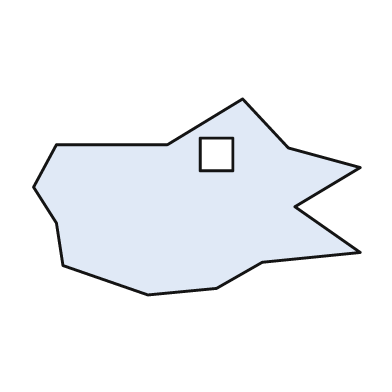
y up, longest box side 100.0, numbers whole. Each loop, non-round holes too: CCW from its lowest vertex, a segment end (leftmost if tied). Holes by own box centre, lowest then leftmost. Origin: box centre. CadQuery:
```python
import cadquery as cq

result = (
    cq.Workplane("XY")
    .moveTo(-15.0, -30.0)
    .lineTo(6.0, -28.0)
    .lineTo(20.0, -20.0)
    .lineTo(50.0, -17.0)
    .lineTo(30.0, -3.0)
    .lineTo(50.0, 9.0)
    .lineTo(28.0, 15.0)
    .lineTo(14.0, 30.0)
    .lineTo(-9.0, 16.0)
    .lineTo(-43.0, 16.0)
    .lineTo(-50.0, 3.0)
    .lineTo(-43.0, -8.0)
    .lineTo(-41.0, -21.0)
    .close()
    .moveTo(1.0, 8.0)
    .lineTo(11.0, 8.0)
    .lineTo(11.0, 18.0)
    .lineTo(1.0, 18.0)
    .close()
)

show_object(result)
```